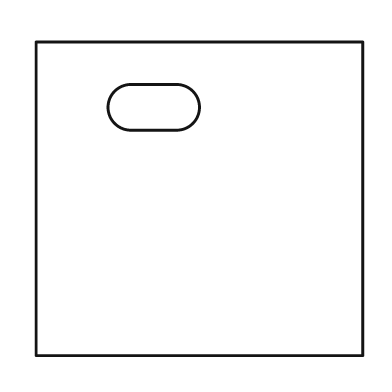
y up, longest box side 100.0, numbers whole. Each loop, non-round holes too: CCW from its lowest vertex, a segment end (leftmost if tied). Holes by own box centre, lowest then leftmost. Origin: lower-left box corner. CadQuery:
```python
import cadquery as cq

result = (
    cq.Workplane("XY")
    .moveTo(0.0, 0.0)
    .lineTo(100.0, 0.0)
    .lineTo(100.0, 96.0)
    .lineTo(0.0, 96.0)
    .close()
    .moveTo(29.0, 69.0)
    .lineTo(43.0, 69.0)
    .threePointArc((50.0, 76.0), (43.0, 83.0))
    .lineTo(29.0, 83.0)
    .threePointArc((22.0, 76.0), (29.0, 69.0))
    .close()
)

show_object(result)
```